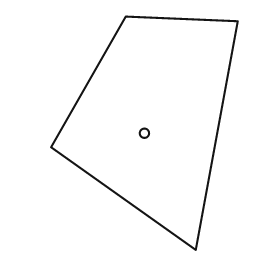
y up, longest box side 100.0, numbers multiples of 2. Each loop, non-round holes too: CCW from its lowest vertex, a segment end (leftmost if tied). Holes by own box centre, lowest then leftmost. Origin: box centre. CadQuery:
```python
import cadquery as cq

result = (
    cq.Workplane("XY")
    .moveTo(22.0, -50.0)
    .lineTo(40.0, 48.0)
    .lineTo(-8.0, 50.0)
    .lineTo(-40.0, -6.0)
    .close()
    .moveTo(0.0, 0.0)
    .circle(2.0)
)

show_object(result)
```